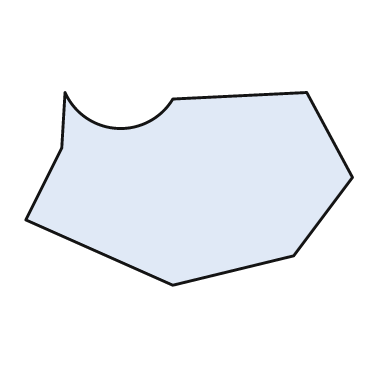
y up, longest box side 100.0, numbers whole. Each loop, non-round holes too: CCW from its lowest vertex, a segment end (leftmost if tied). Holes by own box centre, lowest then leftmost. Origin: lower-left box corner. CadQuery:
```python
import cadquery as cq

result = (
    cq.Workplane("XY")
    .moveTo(45.0, 0.0)
    .lineTo(82.0, 9.0)
    .lineTo(100.0, 33.0)
    .lineTo(86.0, 59.0)
    .lineTo(45.0, 57.0)
    .threePointArc((28.0, 48.0), (12.0, 59.0))
    .lineTo(11.0, 42.0)
    .lineTo(0.0, 20.0)
    .close()
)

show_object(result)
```